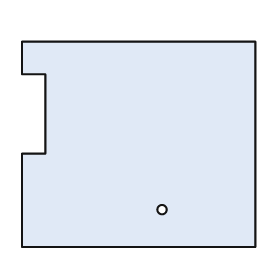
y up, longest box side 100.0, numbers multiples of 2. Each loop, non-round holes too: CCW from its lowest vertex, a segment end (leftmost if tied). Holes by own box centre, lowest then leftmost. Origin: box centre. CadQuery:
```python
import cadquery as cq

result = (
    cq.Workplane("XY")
    .moveTo(-50.0, -44.0)
    .lineTo(50.0, -44.0)
    .lineTo(50.0, 44.0)
    .lineTo(-50.0, 44.0)
    .lineTo(-50.0, 30.0)
    .lineTo(-40.0, 30.0)
    .lineTo(-40.0, -4.0)
    .lineTo(-50.0, -4.0)
    .close()
    .moveTo(10.0, -28.0)
    .circle(2.0)
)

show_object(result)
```